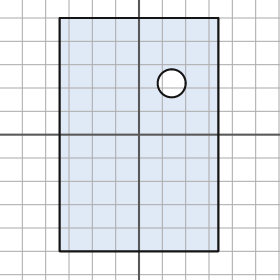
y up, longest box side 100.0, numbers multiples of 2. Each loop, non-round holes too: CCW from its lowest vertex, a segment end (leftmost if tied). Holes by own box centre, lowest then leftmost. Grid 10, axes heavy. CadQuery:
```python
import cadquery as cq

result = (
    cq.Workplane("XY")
    .moveTo(-34.0, -50.0)
    .lineTo(34.0, -50.0)
    .lineTo(34.0, 50.0)
    .lineTo(-34.0, 50.0)
    .close()
    .moveTo(14.0, 22.0)
    .circle(6.0)
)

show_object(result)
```